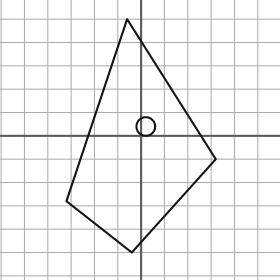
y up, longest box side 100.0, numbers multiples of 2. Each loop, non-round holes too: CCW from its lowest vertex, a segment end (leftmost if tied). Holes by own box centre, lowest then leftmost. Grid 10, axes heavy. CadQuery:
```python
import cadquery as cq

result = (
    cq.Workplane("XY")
    .moveTo(-4.0, -50.0)
    .lineTo(32.0, -10.0)
    .lineTo(-6.0, 50.0)
    .lineTo(-32.0, -28.0)
    .close()
    .moveTo(2.0, 4.0)
    .circle(4.0)
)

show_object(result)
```